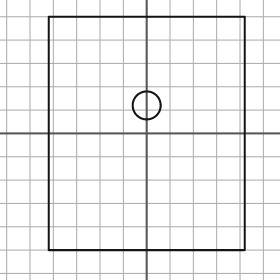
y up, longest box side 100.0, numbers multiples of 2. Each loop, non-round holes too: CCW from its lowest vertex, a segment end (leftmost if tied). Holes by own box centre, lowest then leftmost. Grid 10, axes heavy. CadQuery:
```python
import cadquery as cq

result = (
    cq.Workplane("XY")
    .moveTo(-42.0, -50.0)
    .lineTo(42.0, -50.0)
    .lineTo(42.0, 50.0)
    .lineTo(-42.0, 50.0)
    .close()
    .moveTo(0.0, 12.0)
    .circle(6.0)
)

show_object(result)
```